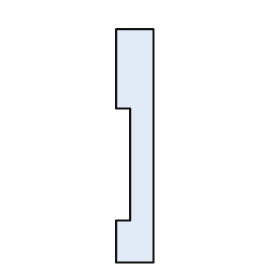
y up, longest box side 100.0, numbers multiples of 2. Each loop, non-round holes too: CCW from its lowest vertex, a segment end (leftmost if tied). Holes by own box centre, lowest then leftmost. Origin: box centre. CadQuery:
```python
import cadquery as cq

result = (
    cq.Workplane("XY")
    .moveTo(-8.0, -50.0)
    .lineTo(8.0, -50.0)
    .lineTo(8.0, 50.0)
    .lineTo(-8.0, 50.0)
    .lineTo(-8.0, 16.0)
    .lineTo(-2.0, 16.0)
    .lineTo(-2.0, -32.0)
    .lineTo(-8.0, -32.0)
    .close()
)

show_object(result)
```